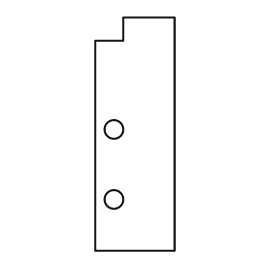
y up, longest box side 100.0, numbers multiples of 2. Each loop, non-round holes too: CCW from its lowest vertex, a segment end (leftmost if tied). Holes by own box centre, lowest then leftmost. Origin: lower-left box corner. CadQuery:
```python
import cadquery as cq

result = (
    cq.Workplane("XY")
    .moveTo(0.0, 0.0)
    .lineTo(34.0, 0.0)
    .lineTo(34.0, 100.0)
    .lineTo(12.0, 100.0)
    .lineTo(12.0, 90.0)
    .lineTo(0.0, 90.0)
    .close()
    .moveTo(8.0, 22.0)
    .circle(4.0)
    .moveTo(8.0, 52.0)
    .circle(4.0)
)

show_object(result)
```